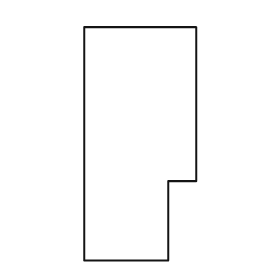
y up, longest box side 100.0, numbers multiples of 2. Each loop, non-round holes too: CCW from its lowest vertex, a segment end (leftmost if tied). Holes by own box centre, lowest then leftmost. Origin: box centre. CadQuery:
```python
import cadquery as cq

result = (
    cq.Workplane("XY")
    .moveTo(-24.0, -50.0)
    .lineTo(12.0, -50.0)
    .lineTo(12.0, -16.0)
    .lineTo(24.0, -16.0)
    .lineTo(24.0, 50.0)
    .lineTo(-24.0, 50.0)
    .close()
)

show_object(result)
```